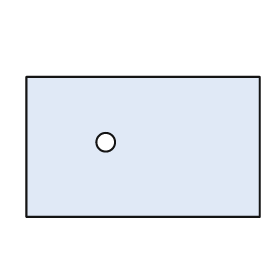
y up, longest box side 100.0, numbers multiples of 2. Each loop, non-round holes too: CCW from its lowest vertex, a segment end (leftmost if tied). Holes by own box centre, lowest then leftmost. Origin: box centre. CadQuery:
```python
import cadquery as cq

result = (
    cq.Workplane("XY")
    .moveTo(-50.0, -30.0)
    .lineTo(50.0, -30.0)
    .lineTo(50.0, 30.0)
    .lineTo(-50.0, 30.0)
    .close()
    .moveTo(-16.0, 2.0)
    .circle(4.0)
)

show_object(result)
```